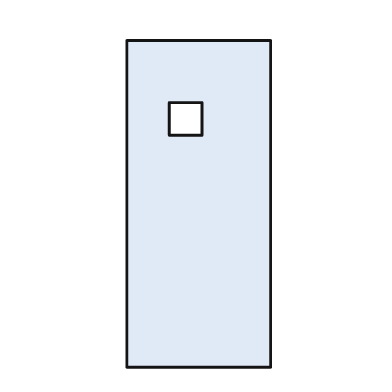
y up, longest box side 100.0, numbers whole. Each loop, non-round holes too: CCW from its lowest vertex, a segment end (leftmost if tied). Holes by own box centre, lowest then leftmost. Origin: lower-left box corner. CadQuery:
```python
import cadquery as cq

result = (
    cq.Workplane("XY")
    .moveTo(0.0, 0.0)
    .lineTo(44.0, 0.0)
    .lineTo(44.0, 100.0)
    .lineTo(0.0, 100.0)
    .close()
    .moveTo(13.0, 71.0)
    .lineTo(23.0, 71.0)
    .lineTo(23.0, 81.0)
    .lineTo(13.0, 81.0)
    .close()
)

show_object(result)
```